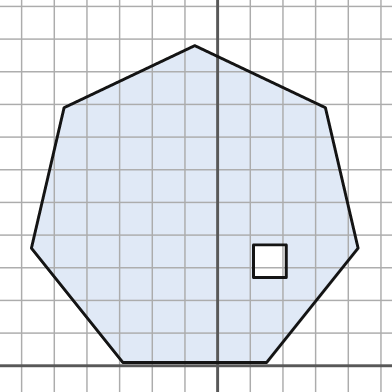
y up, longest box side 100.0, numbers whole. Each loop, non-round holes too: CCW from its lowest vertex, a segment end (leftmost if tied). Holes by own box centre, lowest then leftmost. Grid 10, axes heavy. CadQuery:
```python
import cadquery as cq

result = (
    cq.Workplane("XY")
    .moveTo(-29.0, 1.0)
    .lineTo(15.0, 1.0)
    .lineTo(43.0, 36.0)
    .lineTo(33.0, 79.0)
    .lineTo(-7.0, 98.0)
    .lineTo(-47.0, 79.0)
    .lineTo(-57.0, 36.0)
    .close()
    .moveTo(11.0, 27.0)
    .lineTo(21.0, 27.0)
    .lineTo(21.0, 37.0)
    .lineTo(11.0, 37.0)
    .close()
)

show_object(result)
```